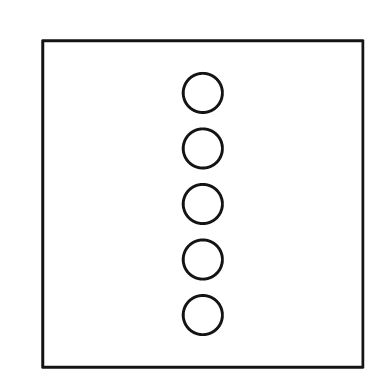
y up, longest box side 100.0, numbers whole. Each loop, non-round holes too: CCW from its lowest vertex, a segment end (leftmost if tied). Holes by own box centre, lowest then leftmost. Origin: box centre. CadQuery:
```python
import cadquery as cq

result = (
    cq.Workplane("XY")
    .moveTo(-49.0, -50.0)
    .lineTo(49.0, -50.0)
    .lineTo(49.0, 50.0)
    .lineTo(-49.0, 50.0)
    .close()
    .moveTo(0.0, -34.0)
    .circle(6.0)
    .moveTo(0.0, -17.0)
    .circle(6.0)
    .moveTo(0.0, 0.0)
    .circle(6.0)
    .moveTo(0.0, 17.0)
    .circle(6.0)
    .moveTo(0.0, 34.0)
    .circle(6.0)
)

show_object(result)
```